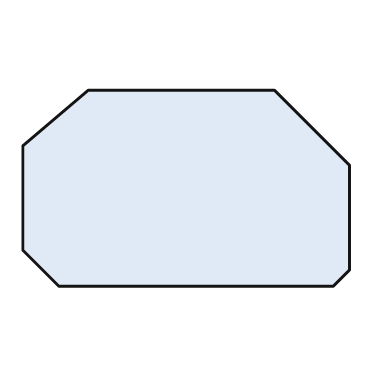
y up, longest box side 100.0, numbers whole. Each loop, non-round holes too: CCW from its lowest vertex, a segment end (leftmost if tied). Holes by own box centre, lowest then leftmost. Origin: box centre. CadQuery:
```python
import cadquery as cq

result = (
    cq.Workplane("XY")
    .moveTo(-39.0, -30.0)
    .lineTo(45.0, -30.0)
    .lineTo(50.0, -25.0)
    .lineTo(50.0, 7.0)
    .lineTo(27.0, 30.0)
    .lineTo(-30.0, 30.0)
    .lineTo(-50.0, 13.0)
    .lineTo(-50.0, -19.0)
    .close()
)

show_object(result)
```